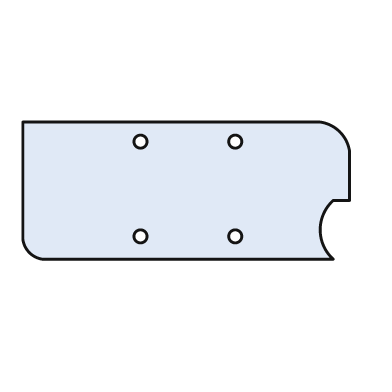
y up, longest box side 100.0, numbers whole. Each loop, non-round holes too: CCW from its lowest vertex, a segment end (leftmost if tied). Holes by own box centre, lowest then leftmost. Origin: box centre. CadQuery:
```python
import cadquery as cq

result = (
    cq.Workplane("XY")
    .moveTo(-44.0, -21.0)
    .lineTo(45.0, -21.0)
    .threePointArc((41.0, -12.0), (45.0, -3.0))
    .lineTo(50.0, -3.0)
    .lineTo(50.0, 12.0)
    .threePointArc((47.0, 18.0), (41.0, 21.0))
    .lineTo(-50.0, 21.0)
    .lineTo(-50.0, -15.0)
    .threePointArc((-48.0, -19.0), (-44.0, -21.0))
    .close()
    .moveTo(-14.0, -14.0)
    .circle(2.0)
    .moveTo(15.0, -14.0)
    .circle(2.0)
    .moveTo(-14.0, 15.0)
    .circle(2.0)
    .moveTo(15.0, 15.0)
    .circle(2.0)
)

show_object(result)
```